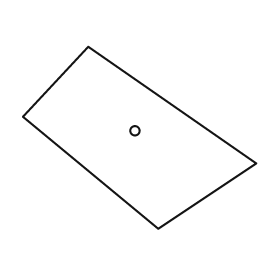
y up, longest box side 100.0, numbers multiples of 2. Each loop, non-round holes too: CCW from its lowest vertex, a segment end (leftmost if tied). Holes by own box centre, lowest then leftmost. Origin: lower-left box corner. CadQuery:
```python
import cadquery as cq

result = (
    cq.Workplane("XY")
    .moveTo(58.0, 0.0)
    .lineTo(100.0, 28.0)
    .lineTo(28.0, 78.0)
    .lineTo(0.0, 48.0)
    .close()
    .moveTo(48.0, 42.0)
    .circle(2.0)
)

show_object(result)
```